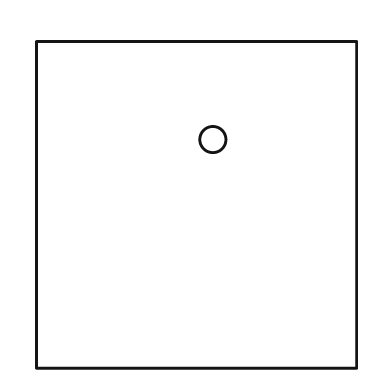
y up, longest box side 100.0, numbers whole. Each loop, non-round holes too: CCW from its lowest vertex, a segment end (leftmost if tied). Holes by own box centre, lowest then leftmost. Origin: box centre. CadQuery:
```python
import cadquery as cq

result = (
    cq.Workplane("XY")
    .moveTo(-49.0, -50.0)
    .lineTo(49.0, -50.0)
    .lineTo(49.0, 50.0)
    .lineTo(-49.0, 50.0)
    .close()
    .moveTo(5.0, 20.0)
    .circle(4.0)
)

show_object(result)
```